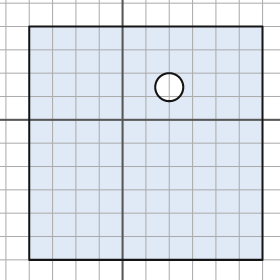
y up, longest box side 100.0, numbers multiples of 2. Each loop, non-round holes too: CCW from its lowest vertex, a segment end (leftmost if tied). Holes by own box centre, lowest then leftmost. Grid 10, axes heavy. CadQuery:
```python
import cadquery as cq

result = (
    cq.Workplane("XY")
    .moveTo(-40.0, -60.0)
    .lineTo(60.0, -60.0)
    .lineTo(60.0, 40.0)
    .lineTo(-40.0, 40.0)
    .close()
    .moveTo(20.0, 14.0)
    .circle(6.0)
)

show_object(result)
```